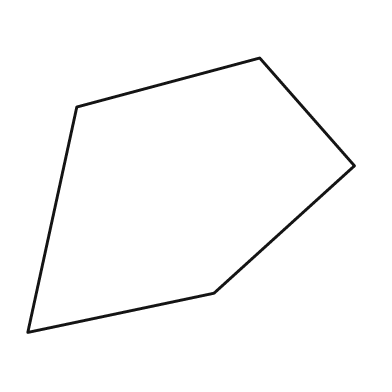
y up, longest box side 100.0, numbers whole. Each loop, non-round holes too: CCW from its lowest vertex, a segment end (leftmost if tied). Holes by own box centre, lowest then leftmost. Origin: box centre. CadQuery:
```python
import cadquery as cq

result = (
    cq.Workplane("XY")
    .moveTo(-50.0, -42.0)
    .lineTo(7.0, -30.0)
    .lineTo(50.0, 9.0)
    .lineTo(21.0, 42.0)
    .lineTo(-35.0, 27.0)
    .close()
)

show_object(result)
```